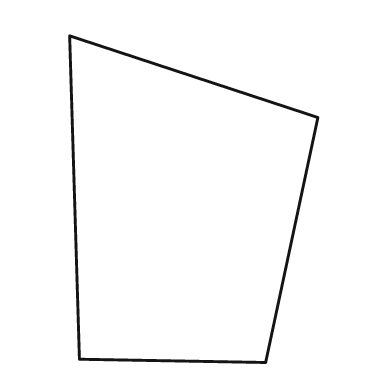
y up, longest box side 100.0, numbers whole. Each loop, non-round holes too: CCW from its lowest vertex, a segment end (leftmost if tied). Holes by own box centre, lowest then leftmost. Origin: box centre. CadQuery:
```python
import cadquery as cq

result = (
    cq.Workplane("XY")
    .moveTo(22.0, -50.0)
    .lineTo(38.0, 25.0)
    .lineTo(-38.0, 50.0)
    .lineTo(-35.0, -49.0)
    .close()
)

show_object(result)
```